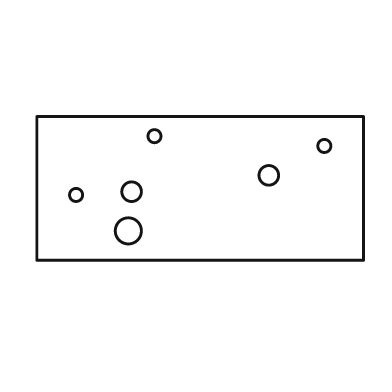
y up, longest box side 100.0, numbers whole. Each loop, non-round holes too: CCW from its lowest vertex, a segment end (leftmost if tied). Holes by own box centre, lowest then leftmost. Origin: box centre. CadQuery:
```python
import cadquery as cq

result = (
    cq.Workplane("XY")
    .moveTo(-50.0, -22.0)
    .lineTo(50.0, -22.0)
    .lineTo(50.0, 22.0)
    .lineTo(-50.0, 22.0)
    .close()
    .moveTo(-22.0, -13.0)
    .circle(4.0)
    .moveTo(-38.0, -2.0)
    .circle(2.0)
    .moveTo(-21.0, -1.0)
    .circle(3.0)
    .moveTo(21.0, 4.0)
    .circle(3.0)
    .moveTo(38.0, 13.0)
    .circle(2.0)
    .moveTo(-14.0, 16.0)
    .circle(2.0)
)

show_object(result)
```